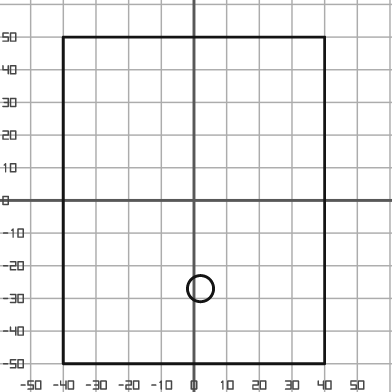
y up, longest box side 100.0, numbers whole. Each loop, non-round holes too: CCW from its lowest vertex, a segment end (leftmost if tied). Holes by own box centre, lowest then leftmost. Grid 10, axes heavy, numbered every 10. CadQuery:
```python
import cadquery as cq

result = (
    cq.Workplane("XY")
    .moveTo(-40.0, -50.0)
    .lineTo(40.0, -50.0)
    .lineTo(40.0, 50.0)
    .lineTo(-40.0, 50.0)
    .close()
    .moveTo(2.0, -27.0)
    .circle(4.0)
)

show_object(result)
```